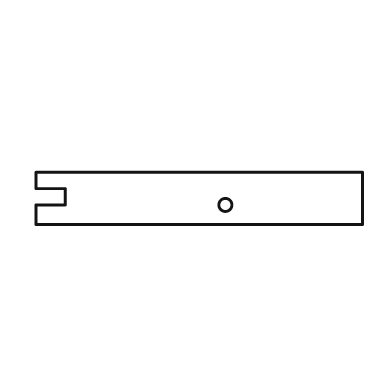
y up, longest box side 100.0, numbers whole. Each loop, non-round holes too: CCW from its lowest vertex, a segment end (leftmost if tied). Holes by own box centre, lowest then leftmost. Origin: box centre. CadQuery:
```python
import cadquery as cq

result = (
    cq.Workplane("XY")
    .moveTo(-50.0, -8.0)
    .lineTo(50.0, -8.0)
    .lineTo(50.0, 8.0)
    .lineTo(-50.0, 8.0)
    .lineTo(-50.0, 3.0)
    .lineTo(-41.0, 3.0)
    .lineTo(-41.0, -2.0)
    .lineTo(-50.0, -2.0)
    .close()
    .moveTo(8.0, -2.0)
    .circle(2.0)
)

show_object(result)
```